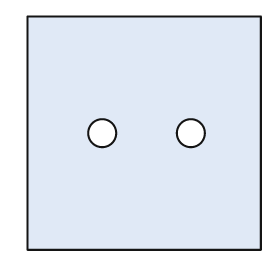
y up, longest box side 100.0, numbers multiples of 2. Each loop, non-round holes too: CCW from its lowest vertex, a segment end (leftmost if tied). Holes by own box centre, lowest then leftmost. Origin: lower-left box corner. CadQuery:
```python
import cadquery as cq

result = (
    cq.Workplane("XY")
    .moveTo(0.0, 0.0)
    .lineTo(100.0, 0.0)
    .lineTo(100.0, 100.0)
    .lineTo(0.0, 100.0)
    .close()
    .moveTo(32.0, 50.0)
    .circle(6.0)
    .moveTo(70.0, 50.0)
    .circle(6.0)
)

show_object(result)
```